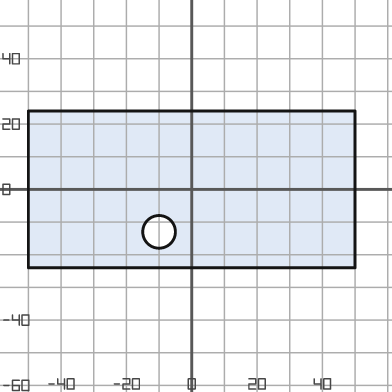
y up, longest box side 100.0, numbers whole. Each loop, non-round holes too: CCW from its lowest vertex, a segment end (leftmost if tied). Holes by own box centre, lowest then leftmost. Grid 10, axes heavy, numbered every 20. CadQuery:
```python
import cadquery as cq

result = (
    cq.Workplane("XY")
    .moveTo(-50.0, -24.0)
    .lineTo(50.0, -24.0)
    .lineTo(50.0, 24.0)
    .lineTo(-50.0, 24.0)
    .close()
    .moveTo(-10.0, -13.0)
    .circle(5.0)
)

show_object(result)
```